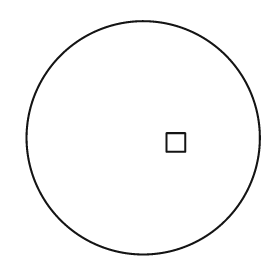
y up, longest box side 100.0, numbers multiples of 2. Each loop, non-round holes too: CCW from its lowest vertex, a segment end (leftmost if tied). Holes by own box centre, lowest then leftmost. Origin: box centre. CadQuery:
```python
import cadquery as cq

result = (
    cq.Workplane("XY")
    .moveTo(0.0, 0.0)
    .circle(50.0)
    .moveTo(10.0, -6.0)
    .lineTo(18.0, -6.0)
    .lineTo(18.0, 2.0)
    .lineTo(10.0, 2.0)
    .close()
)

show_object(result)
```